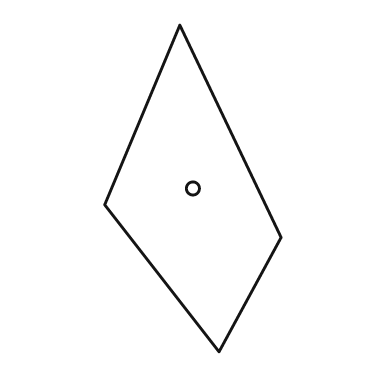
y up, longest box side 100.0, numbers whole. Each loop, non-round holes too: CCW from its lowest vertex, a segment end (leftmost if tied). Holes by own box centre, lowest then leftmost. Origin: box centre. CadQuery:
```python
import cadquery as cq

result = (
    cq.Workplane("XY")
    .moveTo(8.0, -50.0)
    .lineTo(27.0, -15.0)
    .lineTo(-4.0, 50.0)
    .lineTo(-27.0, -5.0)
    .close()
    .moveTo(0.0, 0.0)
    .circle(2.0)
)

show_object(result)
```